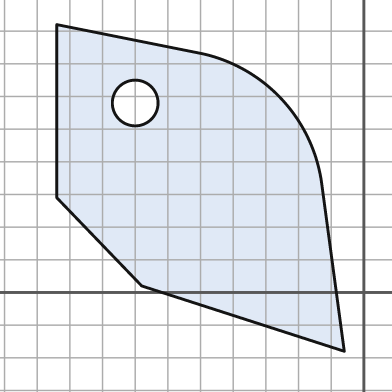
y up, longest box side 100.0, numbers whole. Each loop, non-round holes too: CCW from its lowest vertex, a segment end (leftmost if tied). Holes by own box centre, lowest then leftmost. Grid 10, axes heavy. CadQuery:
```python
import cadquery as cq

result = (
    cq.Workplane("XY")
    .moveTo(-6.0, -18.0)
    .lineTo(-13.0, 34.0)
    .threePointArc((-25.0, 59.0), (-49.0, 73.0))
    .lineTo(-94.0, 82.0)
    .lineTo(-94.0, 29.0)
    .lineTo(-68.0, 2.0)
    .close()
    .moveTo(-70.0, 58.0)
    .circle(7.0)
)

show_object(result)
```